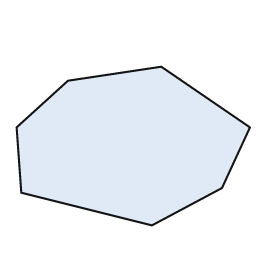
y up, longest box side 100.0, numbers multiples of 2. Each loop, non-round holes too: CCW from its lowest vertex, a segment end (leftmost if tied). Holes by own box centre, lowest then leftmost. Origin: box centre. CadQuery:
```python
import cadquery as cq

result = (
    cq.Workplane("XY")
    .moveTo(8.0, -34.0)
    .lineTo(38.0, -18.0)
    .lineTo(50.0, 8.0)
    .lineTo(12.0, 34.0)
    .lineTo(-28.0, 28.0)
    .lineTo(-50.0, 8.0)
    .lineTo(-48.0, -20.0)
    .close()
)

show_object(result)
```